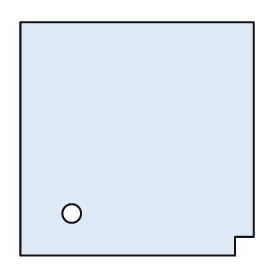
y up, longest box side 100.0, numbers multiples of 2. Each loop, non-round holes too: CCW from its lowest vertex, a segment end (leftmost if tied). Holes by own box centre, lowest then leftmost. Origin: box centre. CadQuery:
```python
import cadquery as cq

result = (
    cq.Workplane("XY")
    .moveTo(-50.0, -50.0)
    .lineTo(42.0, -50.0)
    .lineTo(42.0, -42.0)
    .lineTo(50.0, -42.0)
    .lineTo(50.0, 50.0)
    .lineTo(-50.0, 50.0)
    .close()
    .moveTo(-28.0, -32.0)
    .circle(4.0)
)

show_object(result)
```